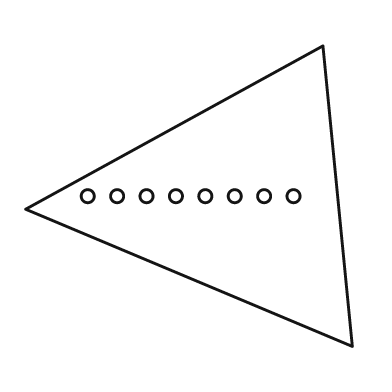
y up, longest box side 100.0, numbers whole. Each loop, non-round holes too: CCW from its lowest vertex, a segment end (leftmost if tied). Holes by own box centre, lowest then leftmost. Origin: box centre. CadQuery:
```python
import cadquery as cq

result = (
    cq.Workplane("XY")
    .moveTo(50.0, -46.0)
    .lineTo(41.0, 46.0)
    .lineTo(-50.0, -4.0)
    .close()
    .moveTo(-31.0, 0.0)
    .circle(2.0)
    .moveTo(-22.0, 0.0)
    .circle(2.0)
    .moveTo(-13.0, 0.0)
    .circle(2.0)
    .moveTo(-4.0, 0.0)
    .circle(2.0)
    .moveTo(5.0, 0.0)
    .circle(2.0)
    .moveTo(14.0, 0.0)
    .circle(2.0)
    .moveTo(23.0, 0.0)
    .circle(2.0)
    .moveTo(32.0, 0.0)
    .circle(2.0)
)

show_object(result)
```